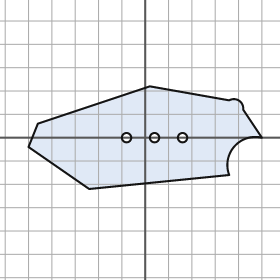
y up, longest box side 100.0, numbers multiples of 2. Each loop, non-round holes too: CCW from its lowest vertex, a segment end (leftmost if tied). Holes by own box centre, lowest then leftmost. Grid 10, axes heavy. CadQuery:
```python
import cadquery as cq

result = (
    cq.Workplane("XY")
    .moveTo(-24.0, -22.0)
    .lineTo(36.0, -16.0)
    .threePointArc((38.0, -4.0), (50.0, 0.0))
    .lineTo(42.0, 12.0)
    .threePointArc((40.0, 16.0), (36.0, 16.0))
    .lineTo(2.0, 22.0)
    .lineTo(-46.0, 6.0)
    .lineTo(-50.0, -4.0)
    .close()
    .moveTo(-8.0, 0.0)
    .circle(2.0)
    .moveTo(4.0, 0.0)
    .circle(2.0)
    .moveTo(16.0, 0.0)
    .circle(2.0)
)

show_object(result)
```